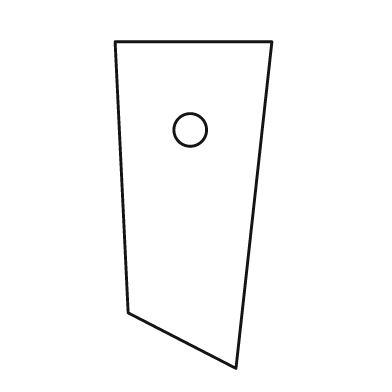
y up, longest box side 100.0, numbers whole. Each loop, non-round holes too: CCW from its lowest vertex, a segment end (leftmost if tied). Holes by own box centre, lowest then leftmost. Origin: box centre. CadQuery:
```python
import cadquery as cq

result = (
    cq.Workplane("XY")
    .moveTo(13.0, -50.0)
    .lineTo(24.0, 50.0)
    .lineTo(-24.0, 50.0)
    .lineTo(-20.0, -33.0)
    .close()
    .moveTo(-1.0, 23.0)
    .circle(5.0)
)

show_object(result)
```